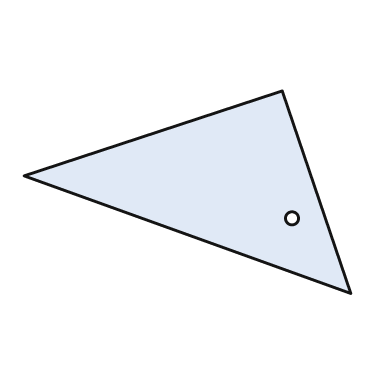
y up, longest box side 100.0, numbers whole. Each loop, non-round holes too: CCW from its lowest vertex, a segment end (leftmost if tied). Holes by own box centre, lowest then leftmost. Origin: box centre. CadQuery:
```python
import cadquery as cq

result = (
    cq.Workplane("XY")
    .moveTo(50.0, -31.0)
    .lineTo(29.0, 31.0)
    .lineTo(-50.0, 5.0)
    .close()
    .moveTo(32.0, -8.0)
    .circle(2.0)
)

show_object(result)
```